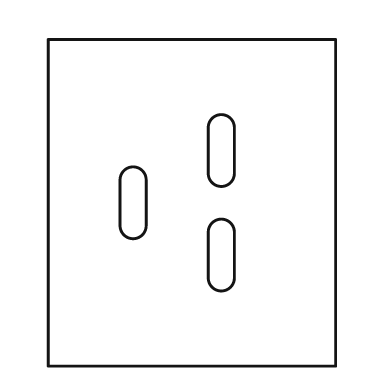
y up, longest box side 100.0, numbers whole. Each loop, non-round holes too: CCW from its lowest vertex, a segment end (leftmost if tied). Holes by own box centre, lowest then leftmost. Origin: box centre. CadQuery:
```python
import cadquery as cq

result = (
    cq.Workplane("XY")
    .moveTo(-44.0, -50.0)
    .lineTo(44.0, -50.0)
    .lineTo(44.0, 50.0)
    .lineTo(-44.0, 50.0)
    .close()
    .moveTo(5.0, -23.0)
    .threePointArc((9.0, -27.0), (13.0, -23.0))
    .lineTo(13.0, -9.0)
    .threePointArc((9.0, -5.0), (5.0, -9.0))
    .close()
    .moveTo(-22.0, -7.0)
    .threePointArc((-18.0, -11.0), (-14.0, -7.0))
    .lineTo(-14.0, 7.0)
    .threePointArc((-18.0, 11.0), (-22.0, 7.0))
    .close()
    .moveTo(5.0, 9.0)
    .threePointArc((9.0, 5.0), (13.0, 9.0))
    .lineTo(13.0, 23.0)
    .threePointArc((9.0, 27.0), (5.0, 23.0))
    .close()
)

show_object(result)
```